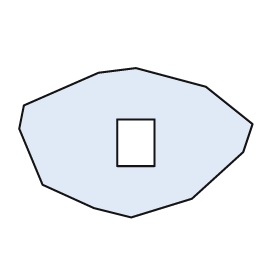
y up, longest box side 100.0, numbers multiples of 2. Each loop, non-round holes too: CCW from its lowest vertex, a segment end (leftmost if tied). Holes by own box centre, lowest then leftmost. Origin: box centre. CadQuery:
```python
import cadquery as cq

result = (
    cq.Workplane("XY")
    .moveTo(-2.0, -32.0)
    .lineTo(24.0, -24.0)
    .lineTo(46.0, -4.0)
    .lineTo(50.0, 8.0)
    .lineTo(30.0, 24.0)
    .lineTo(0.0, 32.0)
    .lineTo(-16.0, 30.0)
    .lineTo(-48.0, 16.0)
    .lineTo(-50.0, 6.0)
    .lineTo(-40.0, -18.0)
    .lineTo(-18.0, -28.0)
    .close()
    .moveTo(-8.0, -10.0)
    .lineTo(8.0, -10.0)
    .lineTo(8.0, 10.0)
    .lineTo(-8.0, 10.0)
    .close()
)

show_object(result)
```